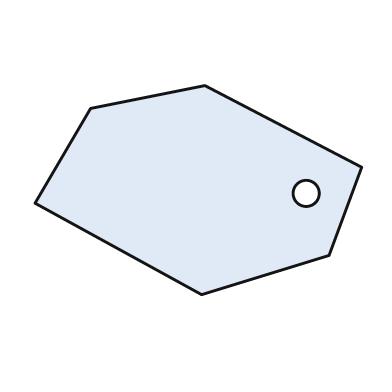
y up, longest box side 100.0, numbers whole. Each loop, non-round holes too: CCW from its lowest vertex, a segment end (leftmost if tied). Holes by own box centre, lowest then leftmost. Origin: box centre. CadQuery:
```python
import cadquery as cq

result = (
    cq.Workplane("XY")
    .moveTo(1.0, -32.0)
    .lineTo(40.0, -20.0)
    .lineTo(50.0, 7.0)
    .lineTo(2.0, 32.0)
    .lineTo(-33.0, 25.0)
    .lineTo(-50.0, -4.0)
    .close()
    .moveTo(33.0, -1.0)
    .circle(4.0)
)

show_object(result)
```